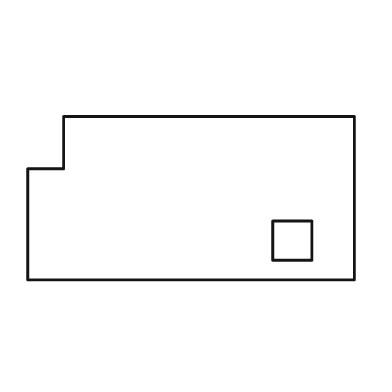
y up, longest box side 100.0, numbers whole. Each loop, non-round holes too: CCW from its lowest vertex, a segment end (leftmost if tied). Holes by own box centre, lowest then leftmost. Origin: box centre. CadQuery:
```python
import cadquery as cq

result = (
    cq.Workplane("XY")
    .moveTo(-50.0, -25.0)
    .lineTo(50.0, -25.0)
    .lineTo(50.0, 25.0)
    .lineTo(-39.0, 25.0)
    .lineTo(-39.0, 9.0)
    .lineTo(-50.0, 9.0)
    .close()
    .moveTo(25.0, -19.0)
    .lineTo(37.0, -19.0)
    .lineTo(37.0, -7.0)
    .lineTo(25.0, -7.0)
    .close()
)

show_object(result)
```